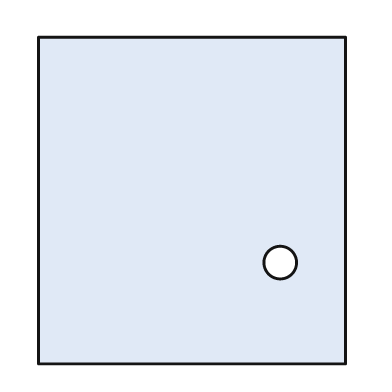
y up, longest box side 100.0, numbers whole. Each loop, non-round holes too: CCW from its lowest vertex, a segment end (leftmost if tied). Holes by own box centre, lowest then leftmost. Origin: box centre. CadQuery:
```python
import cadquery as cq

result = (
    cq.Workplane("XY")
    .moveTo(-47.0, -50.0)
    .lineTo(47.0, -50.0)
    .lineTo(47.0, 50.0)
    .lineTo(-47.0, 50.0)
    .close()
    .moveTo(27.0, -19.0)
    .circle(5.0)
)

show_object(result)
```